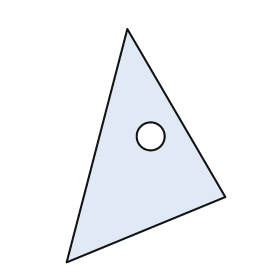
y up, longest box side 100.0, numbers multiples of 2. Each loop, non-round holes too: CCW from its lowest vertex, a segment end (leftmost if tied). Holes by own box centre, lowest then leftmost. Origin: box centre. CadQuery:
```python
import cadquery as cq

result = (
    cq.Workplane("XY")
    .moveTo(-34.0, -50.0)
    .lineTo(34.0, -22.0)
    .lineTo(-8.0, 50.0)
    .close()
    .moveTo(2.0, 4.0)
    .circle(6.0)
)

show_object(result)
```